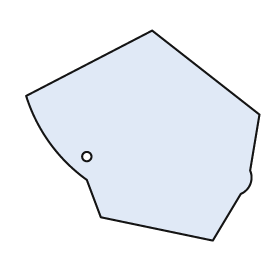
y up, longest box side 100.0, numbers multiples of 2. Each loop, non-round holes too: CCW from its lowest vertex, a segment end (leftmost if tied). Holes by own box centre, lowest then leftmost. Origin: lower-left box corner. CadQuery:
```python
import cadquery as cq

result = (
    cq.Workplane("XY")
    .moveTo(80.0, 0.0)
    .lineTo(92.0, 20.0)
    .threePointArc((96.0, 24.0), (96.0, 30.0))
    .lineTo(100.0, 54.0)
    .lineTo(54.0, 90.0)
    .lineTo(0.0, 62.0)
    .threePointArc((10.0, 42.0), (26.0, 26.0))
    .lineTo(32.0, 10.0)
    .close()
    .moveTo(26.0, 36.0)
    .circle(2.0)
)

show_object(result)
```